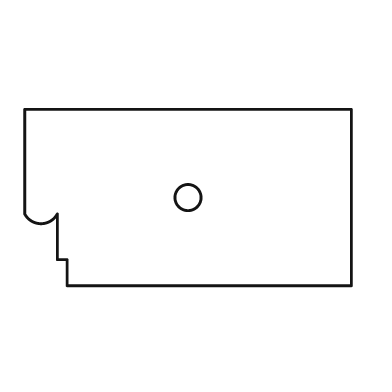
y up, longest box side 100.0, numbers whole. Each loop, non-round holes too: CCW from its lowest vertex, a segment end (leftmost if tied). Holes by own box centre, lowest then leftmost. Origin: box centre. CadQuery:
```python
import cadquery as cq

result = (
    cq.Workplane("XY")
    .moveTo(-37.0, -27.0)
    .lineTo(50.0, -27.0)
    .lineTo(50.0, 27.0)
    .lineTo(-50.0, 27.0)
    .lineTo(-50.0, -5.0)
    .threePointArc((-45.0, -8.0), (-40.0, -5.0))
    .lineTo(-40.0, -19.0)
    .lineTo(-37.0, -19.0)
    .close()
    .moveTo(0.0, 0.0)
    .circle(4.0)
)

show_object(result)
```